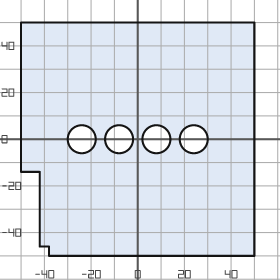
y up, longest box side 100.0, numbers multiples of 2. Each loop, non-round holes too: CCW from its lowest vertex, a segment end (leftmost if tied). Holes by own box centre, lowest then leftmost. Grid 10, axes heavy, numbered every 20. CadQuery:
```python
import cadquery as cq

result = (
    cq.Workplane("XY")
    .moveTo(-38.0, -50.0)
    .lineTo(50.0, -50.0)
    .lineTo(50.0, 50.0)
    .lineTo(-50.0, 50.0)
    .lineTo(-50.0, -14.0)
    .lineTo(-42.0, -14.0)
    .lineTo(-42.0, -46.0)
    .lineTo(-38.0, -46.0)
    .close()
    .moveTo(-24.0, 0.0)
    .circle(6.0)
    .moveTo(-8.0, 0.0)
    .circle(6.0)
    .moveTo(8.0, 0.0)
    .circle(6.0)
    .moveTo(24.0, 0.0)
    .circle(6.0)
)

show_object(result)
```